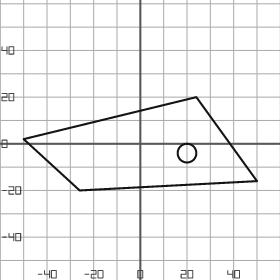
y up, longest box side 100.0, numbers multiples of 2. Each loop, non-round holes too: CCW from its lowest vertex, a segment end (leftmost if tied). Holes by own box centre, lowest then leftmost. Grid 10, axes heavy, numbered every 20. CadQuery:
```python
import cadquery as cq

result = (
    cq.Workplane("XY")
    .moveTo(-26.0, -20.0)
    .lineTo(50.0, -16.0)
    .lineTo(24.0, 20.0)
    .lineTo(-50.0, 2.0)
    .close()
    .moveTo(20.0, -4.0)
    .circle(4.0)
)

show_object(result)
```